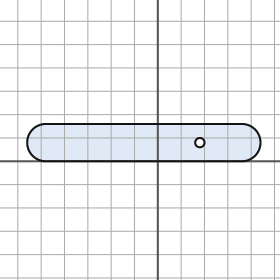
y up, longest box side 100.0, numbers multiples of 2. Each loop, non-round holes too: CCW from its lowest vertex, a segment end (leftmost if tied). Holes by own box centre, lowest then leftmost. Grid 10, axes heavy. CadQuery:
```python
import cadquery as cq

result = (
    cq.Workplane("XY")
    .moveTo(-48.0, 0.0)
    .lineTo(36.0, 0.0)
    .threePointArc((44.0, 8.0), (36.0, 16.0))
    .lineTo(-48.0, 16.0)
    .threePointArc((-56.0, 8.0), (-48.0, 0.0))
    .close()
    .moveTo(18.0, 8.0)
    .circle(2.0)
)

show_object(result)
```